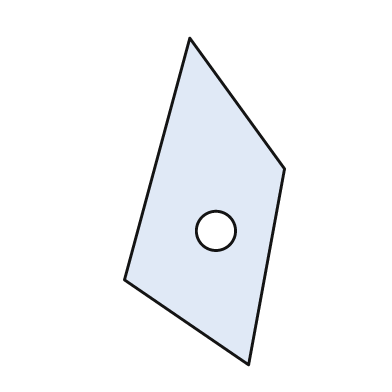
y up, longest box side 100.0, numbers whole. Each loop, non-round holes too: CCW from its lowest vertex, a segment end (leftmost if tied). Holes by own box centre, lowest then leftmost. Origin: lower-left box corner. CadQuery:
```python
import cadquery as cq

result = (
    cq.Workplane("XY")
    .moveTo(38.0, 0.0)
    .lineTo(49.0, 60.0)
    .lineTo(20.0, 100.0)
    .lineTo(0.0, 26.0)
    .close()
    .moveTo(28.0, 41.0)
    .circle(6.0)
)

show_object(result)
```